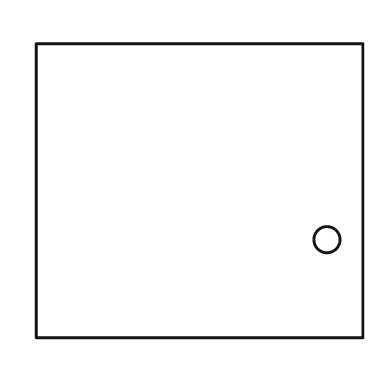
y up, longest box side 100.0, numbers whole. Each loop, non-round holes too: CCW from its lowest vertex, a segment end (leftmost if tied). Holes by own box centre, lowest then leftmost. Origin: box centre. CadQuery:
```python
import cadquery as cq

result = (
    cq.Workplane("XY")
    .moveTo(-50.0, -45.0)
    .lineTo(50.0, -45.0)
    .lineTo(50.0, 45.0)
    .lineTo(-50.0, 45.0)
    .close()
    .moveTo(39.0, -15.0)
    .circle(4.0)
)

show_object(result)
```